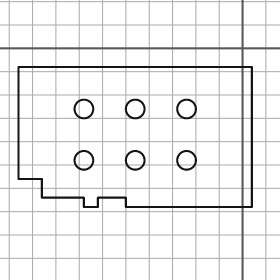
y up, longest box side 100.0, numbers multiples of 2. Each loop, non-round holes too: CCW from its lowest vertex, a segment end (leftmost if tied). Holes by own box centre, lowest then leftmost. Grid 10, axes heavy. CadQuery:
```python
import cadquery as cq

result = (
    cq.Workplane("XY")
    .moveTo(-68.0, -68.0)
    .lineTo(-62.0, -68.0)
    .lineTo(-62.0, -64.0)
    .lineTo(-50.0, -64.0)
    .lineTo(-50.0, -68.0)
    .lineTo(4.0, -68.0)
    .lineTo(4.0, -8.0)
    .lineTo(-96.0, -8.0)
    .lineTo(-96.0, -56.0)
    .lineTo(-86.0, -56.0)
    .lineTo(-86.0, -64.0)
    .lineTo(-68.0, -64.0)
    .close()
    .moveTo(-68.0, -48.0)
    .circle(4.0)
    .moveTo(-46.0, -48.0)
    .circle(4.0)
    .moveTo(-24.0, -48.0)
    .circle(4.0)
    .moveTo(-68.0, -26.0)
    .circle(4.0)
    .moveTo(-46.0, -26.0)
    .circle(4.0)
    .moveTo(-24.0, -26.0)
    .circle(4.0)
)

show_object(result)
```